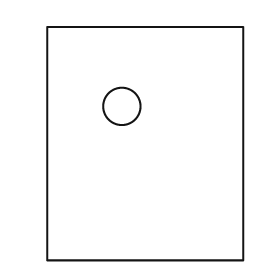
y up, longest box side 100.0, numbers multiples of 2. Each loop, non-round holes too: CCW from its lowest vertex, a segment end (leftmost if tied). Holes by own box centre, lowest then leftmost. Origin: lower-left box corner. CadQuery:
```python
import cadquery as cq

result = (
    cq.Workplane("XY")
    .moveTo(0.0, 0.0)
    .lineTo(84.0, 0.0)
    .lineTo(84.0, 100.0)
    .lineTo(0.0, 100.0)
    .close()
    .moveTo(32.0, 66.0)
    .circle(8.0)
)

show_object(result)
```